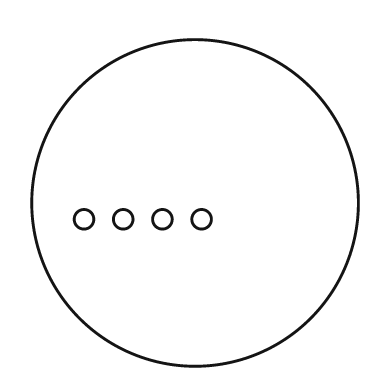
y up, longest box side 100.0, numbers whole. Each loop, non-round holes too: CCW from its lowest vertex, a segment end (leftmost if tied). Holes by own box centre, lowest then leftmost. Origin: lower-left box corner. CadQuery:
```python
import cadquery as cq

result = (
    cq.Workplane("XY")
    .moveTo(50.0, 50.0)
    .circle(50.0)
    .moveTo(16.0, 45.0)
    .circle(3.0)
    .moveTo(28.0, 45.0)
    .circle(3.0)
    .moveTo(40.0, 45.0)
    .circle(3.0)
    .moveTo(52.0, 45.0)
    .circle(3.0)
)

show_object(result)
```